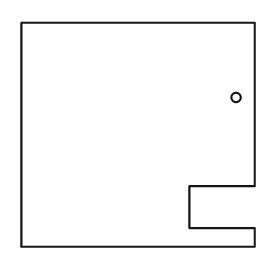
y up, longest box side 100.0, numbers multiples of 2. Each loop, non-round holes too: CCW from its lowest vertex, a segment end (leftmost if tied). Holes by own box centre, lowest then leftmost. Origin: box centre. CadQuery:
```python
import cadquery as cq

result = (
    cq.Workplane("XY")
    .moveTo(-50.0, -48.0)
    .lineTo(50.0, -48.0)
    .lineTo(50.0, -40.0)
    .lineTo(22.0, -40.0)
    .lineTo(22.0, -22.0)
    .lineTo(50.0, -22.0)
    .lineTo(50.0, 48.0)
    .lineTo(-50.0, 48.0)
    .close()
    .moveTo(42.0, 16.0)
    .circle(2.0)
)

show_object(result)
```